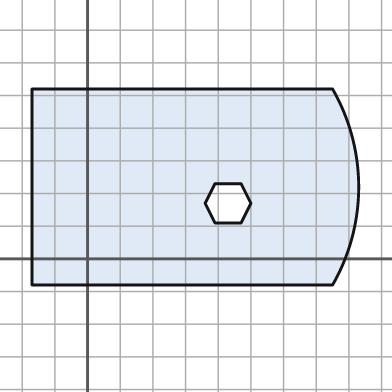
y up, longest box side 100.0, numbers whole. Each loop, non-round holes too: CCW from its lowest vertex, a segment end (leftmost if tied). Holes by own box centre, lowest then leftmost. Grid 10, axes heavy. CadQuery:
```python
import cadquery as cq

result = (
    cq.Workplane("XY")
    .moveTo(-17.0, -8.0)
    .lineTo(75.0, -8.0)
    .threePointArc((83.0, 22.0), (75.0, 52.0))
    .lineTo(-17.0, 52.0)
    .close()
    .moveTo(39.0, 11.0)
    .lineTo(47.0, 11.0)
    .lineTo(50.0, 17.0)
    .lineTo(47.0, 23.0)
    .lineTo(39.0, 23.0)
    .lineTo(36.0, 17.0)
    .close()
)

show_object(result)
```